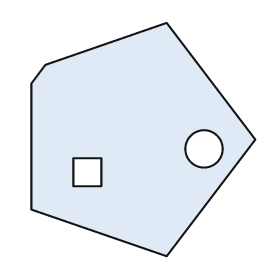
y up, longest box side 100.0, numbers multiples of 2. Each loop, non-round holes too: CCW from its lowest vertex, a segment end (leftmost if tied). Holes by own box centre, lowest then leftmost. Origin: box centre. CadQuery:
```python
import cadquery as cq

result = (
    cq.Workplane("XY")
    .moveTo(10.0, -50.0)
    .lineTo(48.0, 0.0)
    .lineTo(10.0, 50.0)
    .lineTo(-42.0, 32.0)
    .lineTo(-48.0, 24.0)
    .lineTo(-48.0, -30.0)
    .close()
    .moveTo(-30.0, -20.0)
    .lineTo(-18.0, -20.0)
    .lineTo(-18.0, -8.0)
    .lineTo(-30.0, -8.0)
    .close()
    .moveTo(26.0, -4.0)
    .circle(8.0)
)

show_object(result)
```